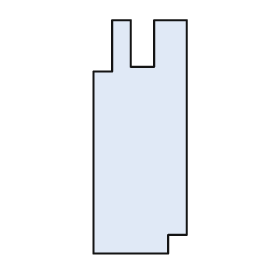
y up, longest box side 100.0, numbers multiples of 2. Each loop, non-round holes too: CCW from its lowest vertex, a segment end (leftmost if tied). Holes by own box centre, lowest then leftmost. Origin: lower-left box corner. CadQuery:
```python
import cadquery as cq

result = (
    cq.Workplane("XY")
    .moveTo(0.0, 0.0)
    .lineTo(32.0, 0.0)
    .lineTo(32.0, 8.0)
    .lineTo(40.0, 8.0)
    .lineTo(40.0, 100.0)
    .lineTo(26.0, 100.0)
    .lineTo(26.0, 80.0)
    .lineTo(16.0, 80.0)
    .lineTo(16.0, 100.0)
    .lineTo(8.0, 100.0)
    .lineTo(8.0, 78.0)
    .lineTo(0.0, 78.0)
    .close()
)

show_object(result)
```